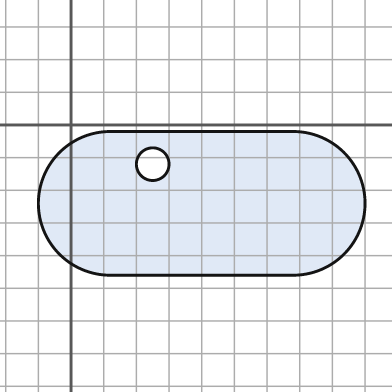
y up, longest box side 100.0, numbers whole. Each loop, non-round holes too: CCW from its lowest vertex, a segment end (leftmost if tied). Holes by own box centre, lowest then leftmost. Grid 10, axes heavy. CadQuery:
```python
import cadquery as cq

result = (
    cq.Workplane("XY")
    .moveTo(12.0, -46.0)
    .lineTo(68.0, -46.0)
    .threePointArc((90.0, -24.0), (68.0, -2.0))
    .lineTo(12.0, -2.0)
    .threePointArc((-10.0, -24.0), (12.0, -46.0))
    .close()
    .moveTo(25.0, -12.0)
    .circle(5.0)
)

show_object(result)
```